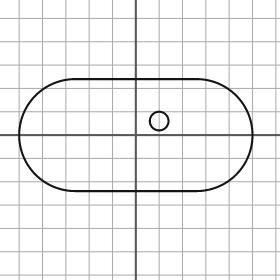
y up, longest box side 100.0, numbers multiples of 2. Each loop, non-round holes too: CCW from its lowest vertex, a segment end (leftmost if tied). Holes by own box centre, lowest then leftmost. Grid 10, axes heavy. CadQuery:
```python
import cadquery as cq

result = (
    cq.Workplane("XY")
    .moveTo(-26.0, -24.0)
    .lineTo(26.0, -24.0)
    .threePointArc((50.0, 0.0), (26.0, 24.0))
    .lineTo(-26.0, 24.0)
    .threePointArc((-50.0, 0.0), (-26.0, -24.0))
    .close()
    .moveTo(10.0, 6.0)
    .circle(4.0)
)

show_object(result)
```